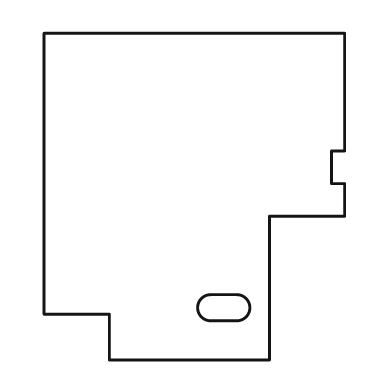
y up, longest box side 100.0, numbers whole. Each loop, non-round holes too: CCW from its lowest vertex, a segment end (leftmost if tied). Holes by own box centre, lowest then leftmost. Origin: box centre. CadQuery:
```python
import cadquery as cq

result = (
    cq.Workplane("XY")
    .moveTo(-26.0, -50.0)
    .lineTo(23.0, -50.0)
    .lineTo(23.0, -6.0)
    .lineTo(46.0, -6.0)
    .lineTo(46.0, 4.0)
    .lineTo(42.0, 4.0)
    .lineTo(42.0, 14.0)
    .lineTo(46.0, 14.0)
    .lineTo(46.0, 50.0)
    .lineTo(-46.0, 50.0)
    .lineTo(-46.0, -36.0)
    .lineTo(-26.0, -36.0)
    .close()
    .moveTo(5.0, -38.0)
    .lineTo(13.0, -38.0)
    .threePointArc((17.0, -34.0), (13.0, -30.0))
    .lineTo(5.0, -30.0)
    .threePointArc((1.0, -34.0), (5.0, -38.0))
    .close()
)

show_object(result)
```